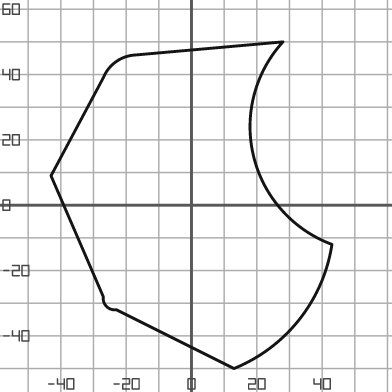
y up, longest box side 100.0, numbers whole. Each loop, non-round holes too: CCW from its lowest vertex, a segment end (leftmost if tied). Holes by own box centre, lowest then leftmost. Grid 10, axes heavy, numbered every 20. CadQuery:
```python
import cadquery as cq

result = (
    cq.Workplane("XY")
    .moveTo(13.0, -50.0)
    .threePointArc((33.0, -35.0), (43.0, -12.0))
    .threePointArc((19.0, 15.0), (28.0, 50.0))
    .lineTo(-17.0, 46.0)
    .threePointArc((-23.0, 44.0), (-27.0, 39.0))
    .lineTo(-43.0, 9.0)
    .lineTo(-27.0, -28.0)
    .threePointArc((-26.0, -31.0), (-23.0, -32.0))
    .close()
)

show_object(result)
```